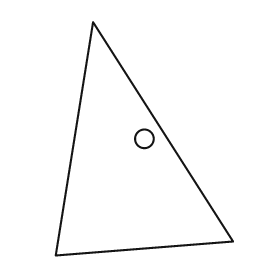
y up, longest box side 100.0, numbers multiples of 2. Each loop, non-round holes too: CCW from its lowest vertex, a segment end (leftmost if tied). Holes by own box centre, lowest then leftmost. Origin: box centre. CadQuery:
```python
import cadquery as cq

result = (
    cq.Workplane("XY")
    .moveTo(-38.0, -50.0)
    .lineTo(38.0, -44.0)
    .lineTo(-22.0, 50.0)
    .close()
    .moveTo(0.0, 0.0)
    .circle(4.0)
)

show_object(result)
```